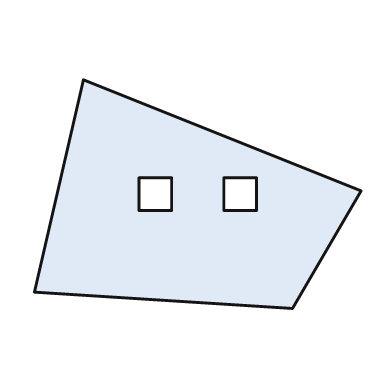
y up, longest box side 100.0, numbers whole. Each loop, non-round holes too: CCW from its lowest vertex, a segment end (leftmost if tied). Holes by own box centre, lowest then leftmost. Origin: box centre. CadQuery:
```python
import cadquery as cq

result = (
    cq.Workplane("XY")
    .moveTo(29.0, -35.0)
    .lineTo(50.0, 1.0)
    .lineTo(-35.0, 35.0)
    .lineTo(-50.0, -30.0)
    .close()
    .moveTo(-18.0, -5.0)
    .lineTo(-8.0, -5.0)
    .lineTo(-8.0, 5.0)
    .lineTo(-18.0, 5.0)
    .close()
    .moveTo(8.0, -5.0)
    .lineTo(18.0, -5.0)
    .lineTo(18.0, 5.0)
    .lineTo(8.0, 5.0)
    .close()
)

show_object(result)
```